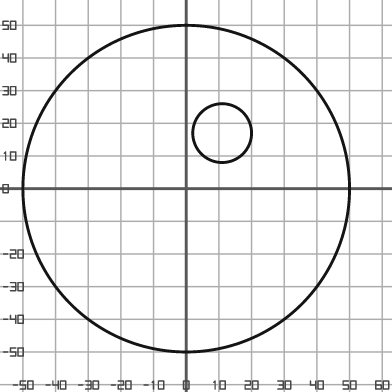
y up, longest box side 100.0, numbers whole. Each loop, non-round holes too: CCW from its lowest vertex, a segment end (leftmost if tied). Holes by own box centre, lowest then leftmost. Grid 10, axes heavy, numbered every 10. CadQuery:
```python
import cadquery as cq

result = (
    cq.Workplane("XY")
    .moveTo(0.0, 0.0)
    .circle(50.0)
    .moveTo(11.0, 17.0)
    .circle(9.0)
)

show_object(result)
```